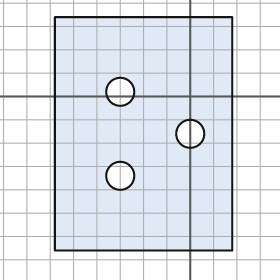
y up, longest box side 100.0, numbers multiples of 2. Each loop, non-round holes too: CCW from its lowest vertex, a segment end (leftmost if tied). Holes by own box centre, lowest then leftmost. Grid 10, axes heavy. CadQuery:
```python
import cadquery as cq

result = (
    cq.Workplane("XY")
    .moveTo(-58.0, -66.0)
    .lineTo(18.0, -66.0)
    .lineTo(18.0, 34.0)
    .lineTo(-58.0, 34.0)
    .close()
    .moveTo(-30.0, -34.0)
    .circle(6.0)
    .moveTo(0.0, -16.0)
    .circle(6.0)
    .moveTo(-30.0, 2.0)
    .circle(6.0)
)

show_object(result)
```